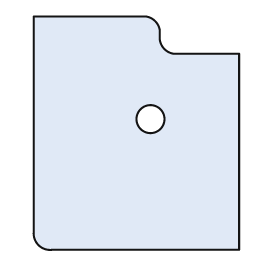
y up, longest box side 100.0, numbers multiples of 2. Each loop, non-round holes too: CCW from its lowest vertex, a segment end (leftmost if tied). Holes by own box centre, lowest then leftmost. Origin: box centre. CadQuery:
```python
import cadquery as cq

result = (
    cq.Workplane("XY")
    .moveTo(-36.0, -50.0)
    .lineTo(44.0, -50.0)
    .lineTo(44.0, 34.0)
    .lineTo(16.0, 34.0)
    .threePointArc((12.0, 36.0), (10.0, 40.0))
    .lineTo(10.0, 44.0)
    .threePointArc((8.0, 48.0), (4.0, 50.0))
    .lineTo(-44.0, 50.0)
    .lineTo(-44.0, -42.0)
    .threePointArc((-42.0, -48.0), (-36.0, -50.0))
    .close()
    .moveTo(6.0, 6.0)
    .circle(6.0)
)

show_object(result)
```